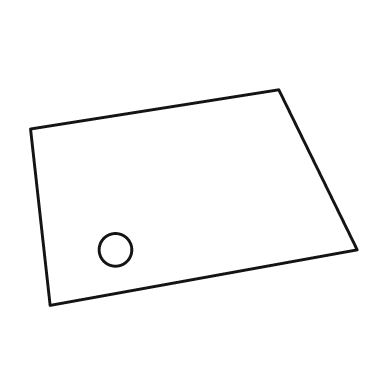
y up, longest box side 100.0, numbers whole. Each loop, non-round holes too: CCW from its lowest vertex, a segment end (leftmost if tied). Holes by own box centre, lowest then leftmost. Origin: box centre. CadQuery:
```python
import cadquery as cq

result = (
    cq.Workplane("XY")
    .moveTo(-44.0, -33.0)
    .lineTo(50.0, -16.0)
    .lineTo(26.0, 33.0)
    .lineTo(-50.0, 21.0)
    .close()
    .moveTo(-24.0, -16.0)
    .circle(5.0)
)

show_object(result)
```